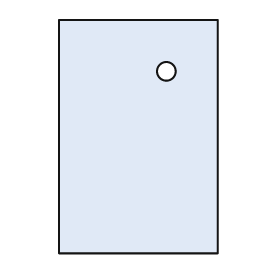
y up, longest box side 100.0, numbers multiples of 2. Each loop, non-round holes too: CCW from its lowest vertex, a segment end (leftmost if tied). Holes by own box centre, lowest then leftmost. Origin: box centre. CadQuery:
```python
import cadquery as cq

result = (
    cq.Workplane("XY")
    .moveTo(-34.0, -50.0)
    .lineTo(34.0, -50.0)
    .lineTo(34.0, 50.0)
    .lineTo(-34.0, 50.0)
    .close()
    .moveTo(12.0, 28.0)
    .circle(4.0)
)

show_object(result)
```